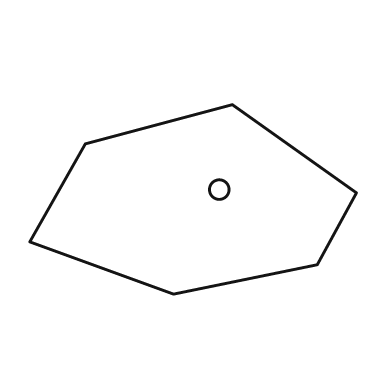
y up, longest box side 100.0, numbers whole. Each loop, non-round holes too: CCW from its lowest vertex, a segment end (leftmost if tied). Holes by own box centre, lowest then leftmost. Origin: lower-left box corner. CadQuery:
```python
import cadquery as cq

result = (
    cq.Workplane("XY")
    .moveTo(44.0, 0.0)
    .lineTo(88.0, 9.0)
    .lineTo(100.0, 31.0)
    .lineTo(62.0, 58.0)
    .lineTo(17.0, 46.0)
    .lineTo(0.0, 16.0)
    .close()
    .moveTo(58.0, 32.0)
    .circle(3.0)
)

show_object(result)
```